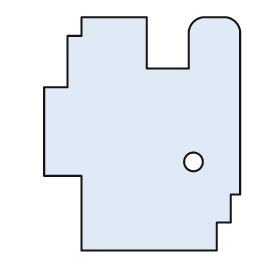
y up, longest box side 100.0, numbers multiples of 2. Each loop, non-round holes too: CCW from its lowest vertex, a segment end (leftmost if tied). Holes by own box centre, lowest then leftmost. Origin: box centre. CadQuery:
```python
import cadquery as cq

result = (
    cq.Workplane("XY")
    .moveTo(-26.0, -50.0)
    .lineTo(32.0, -50.0)
    .lineTo(32.0, -38.0)
    .lineTo(38.0, -38.0)
    .lineTo(38.0, -26.0)
    .lineTo(42.0, -26.0)
    .lineTo(42.0, 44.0)
    .threePointArc((40.0, 48.0), (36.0, 50.0))
    .lineTo(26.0, 50.0)
    .threePointArc((22.0, 48.0), (20.0, 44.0))
    .lineTo(20.0, 28.0)
    .lineTo(2.0, 28.0)
    .lineTo(2.0, 50.0)
    .lineTo(-26.0, 50.0)
    .lineTo(-26.0, 42.0)
    .lineTo(-32.0, 42.0)
    .lineTo(-32.0, 20.0)
    .lineTo(-42.0, 20.0)
    .lineTo(-42.0, -18.0)
    .lineTo(-26.0, -18.0)
    .close()
    .moveTo(22.0, -12.0)
    .circle(4.0)
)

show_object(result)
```